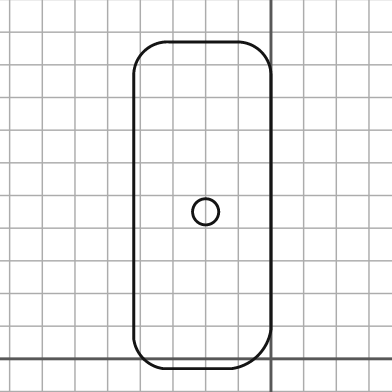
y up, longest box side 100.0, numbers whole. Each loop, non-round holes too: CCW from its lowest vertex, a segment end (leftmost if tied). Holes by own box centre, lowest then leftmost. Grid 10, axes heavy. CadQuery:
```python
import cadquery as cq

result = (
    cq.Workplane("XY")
    .moveTo(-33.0, -3.0)
    .lineTo(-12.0, -3.0)
    .threePointArc((-4.0, 1.0), (0.0, 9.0))
    .lineTo(0.0, 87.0)
    .threePointArc((-3.0, 94.0), (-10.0, 97.0))
    .lineTo(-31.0, 97.0)
    .threePointArc((-39.0, 94.0), (-42.0, 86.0))
    .lineTo(-42.0, 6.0)
    .threePointArc((-39.0, 0.0), (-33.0, -3.0))
    .close()
    .moveTo(-20.0, 45.0)
    .circle(4.0)
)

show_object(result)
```